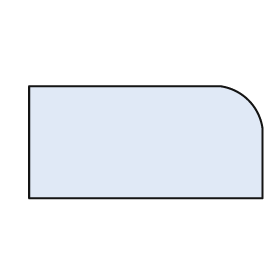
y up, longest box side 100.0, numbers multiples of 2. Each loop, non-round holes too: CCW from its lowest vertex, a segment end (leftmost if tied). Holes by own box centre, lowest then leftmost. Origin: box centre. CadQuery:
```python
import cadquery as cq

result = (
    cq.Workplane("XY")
    .moveTo(-50.0, -24.0)
    .lineTo(50.0, -24.0)
    .lineTo(50.0, 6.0)
    .threePointArc((44.0, 18.0), (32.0, 24.0))
    .lineTo(-50.0, 24.0)
    .close()
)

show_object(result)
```